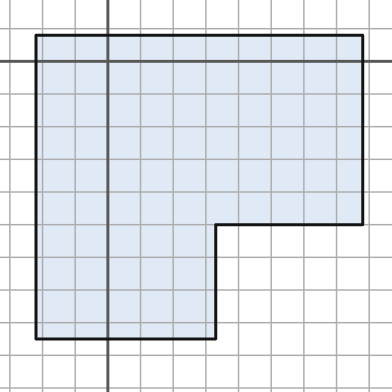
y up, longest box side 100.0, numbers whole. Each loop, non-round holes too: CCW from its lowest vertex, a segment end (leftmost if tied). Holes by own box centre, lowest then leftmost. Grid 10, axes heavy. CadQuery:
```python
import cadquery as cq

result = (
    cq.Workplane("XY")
    .moveTo(-22.0, -85.0)
    .lineTo(33.0, -85.0)
    .lineTo(33.0, -50.0)
    .lineTo(78.0, -50.0)
    .lineTo(78.0, 8.0)
    .lineTo(-22.0, 8.0)
    .close()
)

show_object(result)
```